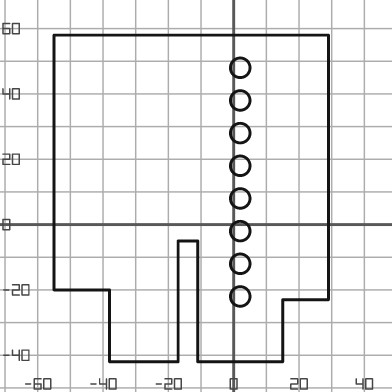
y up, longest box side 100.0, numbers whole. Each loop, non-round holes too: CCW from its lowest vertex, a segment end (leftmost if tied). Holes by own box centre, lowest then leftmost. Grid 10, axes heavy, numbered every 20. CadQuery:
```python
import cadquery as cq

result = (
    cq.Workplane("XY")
    .moveTo(-38.0, -42.0)
    .lineTo(-17.0, -42.0)
    .lineTo(-17.0, -5.0)
    .lineTo(-11.0, -5.0)
    .lineTo(-11.0, -42.0)
    .lineTo(15.0, -42.0)
    .lineTo(15.0, -23.0)
    .lineTo(29.0, -23.0)
    .lineTo(29.0, 58.0)
    .lineTo(-55.0, 58.0)
    .lineTo(-55.0, -20.0)
    .lineTo(-38.0, -20.0)
    .close()
    .moveTo(2.0, -22.0)
    .circle(3.0)
    .moveTo(2.0, -12.0)
    .circle(3.0)
    .moveTo(2.0, -2.0)
    .circle(3.0)
    .moveTo(2.0, 8.0)
    .circle(3.0)
    .moveTo(2.0, 18.0)
    .circle(3.0)
    .moveTo(2.0, 28.0)
    .circle(3.0)
    .moveTo(2.0, 38.0)
    .circle(3.0)
    .moveTo(2.0, 48.0)
    .circle(3.0)
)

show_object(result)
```